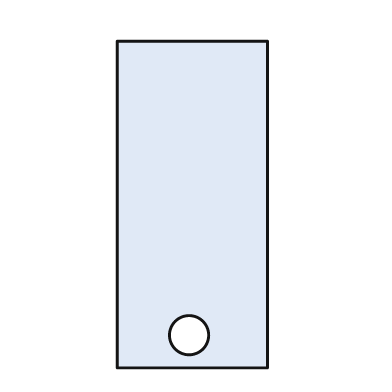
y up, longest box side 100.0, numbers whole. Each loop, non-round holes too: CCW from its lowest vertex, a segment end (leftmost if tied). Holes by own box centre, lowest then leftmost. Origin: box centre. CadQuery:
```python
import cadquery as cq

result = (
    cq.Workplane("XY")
    .moveTo(-23.0, -50.0)
    .lineTo(23.0, -50.0)
    .lineTo(23.0, 50.0)
    .lineTo(-23.0, 50.0)
    .close()
    .moveTo(-1.0, -40.0)
    .circle(6.0)
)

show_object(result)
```